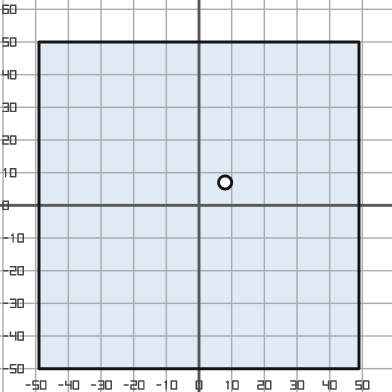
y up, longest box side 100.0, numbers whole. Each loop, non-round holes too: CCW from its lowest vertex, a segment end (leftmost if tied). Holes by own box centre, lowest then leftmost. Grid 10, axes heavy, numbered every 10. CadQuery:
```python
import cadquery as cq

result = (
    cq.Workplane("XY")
    .moveTo(-49.0, -50.0)
    .lineTo(49.0, -50.0)
    .lineTo(49.0, 50.0)
    .lineTo(-49.0, 50.0)
    .close()
    .moveTo(8.0, 7.0)
    .circle(2.0)
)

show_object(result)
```